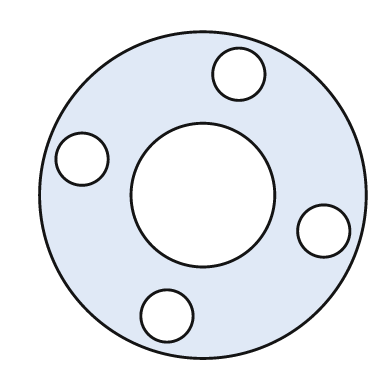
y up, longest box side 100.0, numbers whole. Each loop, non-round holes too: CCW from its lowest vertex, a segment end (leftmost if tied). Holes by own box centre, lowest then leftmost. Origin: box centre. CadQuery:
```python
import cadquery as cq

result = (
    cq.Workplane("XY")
    .moveTo(0.0, 0.0)
    .circle(50.0)
    .moveTo(-11.0, -37.0)
    .circle(8.0)
    .moveTo(37.0, -11.0)
    .circle(8.0)
    .moveTo(0.0, 0.0)
    .circle(22.0)
    .moveTo(-37.0, 11.0)
    .circle(8.0)
    .moveTo(11.0, 37.0)
    .circle(8.0)
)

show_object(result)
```